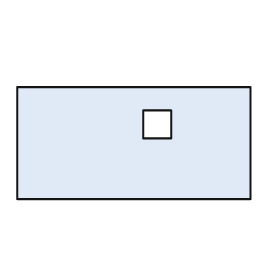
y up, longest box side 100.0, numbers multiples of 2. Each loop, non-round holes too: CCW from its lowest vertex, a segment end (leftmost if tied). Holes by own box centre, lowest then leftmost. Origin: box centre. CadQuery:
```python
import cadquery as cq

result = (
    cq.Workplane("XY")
    .moveTo(-50.0, -24.0)
    .lineTo(50.0, -24.0)
    .lineTo(50.0, 24.0)
    .lineTo(-50.0, 24.0)
    .close()
    .moveTo(4.0, 2.0)
    .lineTo(16.0, 2.0)
    .lineTo(16.0, 14.0)
    .lineTo(4.0, 14.0)
    .close()
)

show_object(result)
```